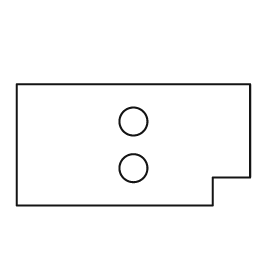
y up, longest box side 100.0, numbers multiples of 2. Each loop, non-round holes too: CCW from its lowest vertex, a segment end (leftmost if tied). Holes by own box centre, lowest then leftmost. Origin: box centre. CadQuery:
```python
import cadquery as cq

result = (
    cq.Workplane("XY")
    .moveTo(-50.0, -26.0)
    .lineTo(34.0, -26.0)
    .lineTo(34.0, -14.0)
    .lineTo(50.0, -14.0)
    .lineTo(50.0, 26.0)
    .lineTo(-50.0, 26.0)
    .close()
    .moveTo(0.0, -10.0)
    .circle(6.0)
    .moveTo(0.0, 10.0)
    .circle(6.0)
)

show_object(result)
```